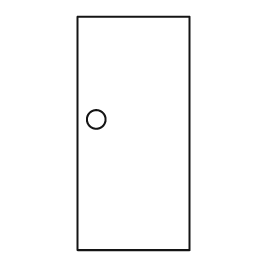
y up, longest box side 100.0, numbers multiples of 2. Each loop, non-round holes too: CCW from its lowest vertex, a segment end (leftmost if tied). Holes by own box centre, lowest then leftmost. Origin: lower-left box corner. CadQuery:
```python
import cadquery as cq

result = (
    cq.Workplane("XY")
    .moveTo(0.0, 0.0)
    .lineTo(48.0, 0.0)
    .lineTo(48.0, 100.0)
    .lineTo(0.0, 100.0)
    .close()
    .moveTo(8.0, 56.0)
    .circle(4.0)
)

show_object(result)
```